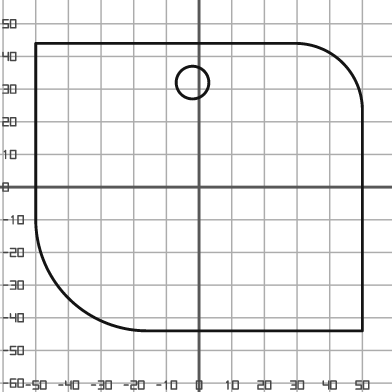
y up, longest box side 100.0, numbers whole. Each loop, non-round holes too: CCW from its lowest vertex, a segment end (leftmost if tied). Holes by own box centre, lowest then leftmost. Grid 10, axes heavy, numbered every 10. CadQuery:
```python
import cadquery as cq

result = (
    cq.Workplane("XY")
    .moveTo(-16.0, -44.0)
    .lineTo(50.0, -44.0)
    .lineTo(50.0, 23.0)
    .threePointArc((44.0, 38.0), (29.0, 44.0))
    .lineTo(-50.0, 44.0)
    .lineTo(-50.0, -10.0)
    .threePointArc((-40.0, -34.0), (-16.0, -44.0))
    .close()
    .moveTo(-2.0, 32.0)
    .circle(5.0)
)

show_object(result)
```